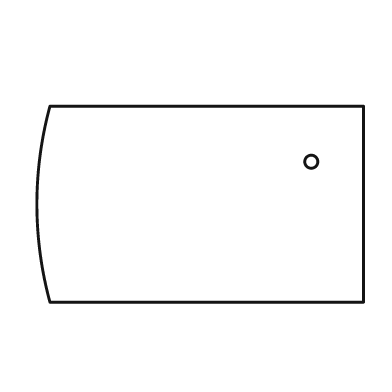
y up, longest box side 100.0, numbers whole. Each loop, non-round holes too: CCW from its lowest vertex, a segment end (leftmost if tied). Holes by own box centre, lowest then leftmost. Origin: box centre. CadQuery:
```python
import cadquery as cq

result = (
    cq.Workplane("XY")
    .moveTo(-46.0, -30.0)
    .lineTo(50.0, -30.0)
    .lineTo(50.0, 30.0)
    .lineTo(-46.0, 30.0)
    .threePointArc((-50.0, 0.0), (-46.0, -30.0))
    .close()
    .moveTo(34.0, 13.0)
    .circle(2.0)
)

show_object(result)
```